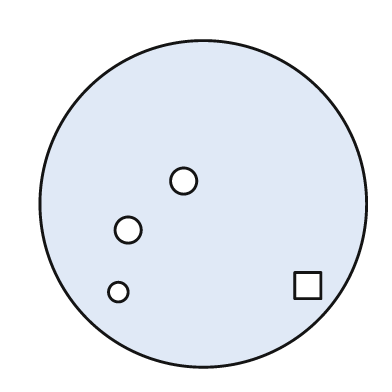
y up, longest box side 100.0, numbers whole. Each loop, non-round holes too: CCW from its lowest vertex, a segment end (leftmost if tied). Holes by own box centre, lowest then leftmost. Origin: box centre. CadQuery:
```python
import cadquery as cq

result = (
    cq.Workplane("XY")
    .moveTo(0.0, 0.0)
    .circle(50.0)
    .moveTo(-26.0, -27.0)
    .circle(3.0)
    .moveTo(28.0, -29.0)
    .lineTo(36.0, -29.0)
    .lineTo(36.0, -21.0)
    .lineTo(28.0, -21.0)
    .close()
    .moveTo(-23.0, -8.0)
    .circle(4.0)
    .moveTo(-6.0, 7.0)
    .circle(4.0)
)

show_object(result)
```